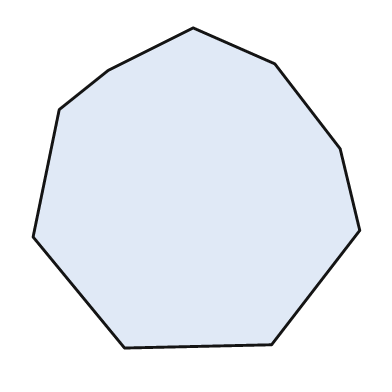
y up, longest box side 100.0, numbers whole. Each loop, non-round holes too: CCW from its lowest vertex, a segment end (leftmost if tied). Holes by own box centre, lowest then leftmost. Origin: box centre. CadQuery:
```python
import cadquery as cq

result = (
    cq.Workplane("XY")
    .moveTo(-22.0, -49.0)
    .lineTo(23.0, -48.0)
    .lineTo(50.0, -13.0)
    .lineTo(44.0, 12.0)
    .lineTo(24.0, 38.0)
    .lineTo(-1.0, 49.0)
    .lineTo(-27.0, 36.0)
    .lineTo(-42.0, 24.0)
    .lineTo(-50.0, -15.0)
    .close()
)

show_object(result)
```